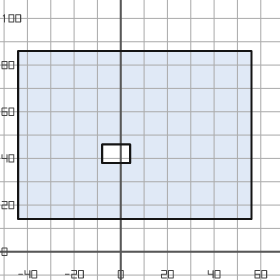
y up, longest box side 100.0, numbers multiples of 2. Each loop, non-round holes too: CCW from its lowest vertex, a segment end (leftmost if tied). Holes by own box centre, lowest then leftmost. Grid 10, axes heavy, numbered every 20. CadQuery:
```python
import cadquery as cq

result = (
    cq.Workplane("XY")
    .moveTo(-44.0, 14.0)
    .lineTo(56.0, 14.0)
    .lineTo(56.0, 86.0)
    .lineTo(-44.0, 86.0)
    .close()
    .moveTo(-8.0, 38.0)
    .lineTo(4.0, 38.0)
    .lineTo(4.0, 46.0)
    .lineTo(-8.0, 46.0)
    .close()
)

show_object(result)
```